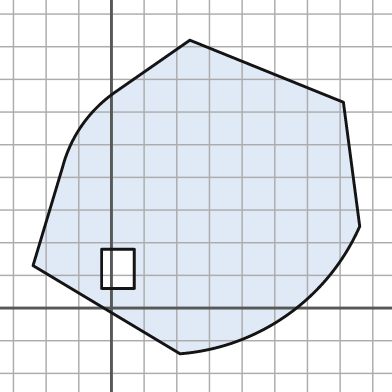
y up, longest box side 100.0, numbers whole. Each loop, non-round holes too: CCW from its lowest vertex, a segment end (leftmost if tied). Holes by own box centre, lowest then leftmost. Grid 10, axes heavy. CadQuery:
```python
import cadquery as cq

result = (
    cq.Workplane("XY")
    .moveTo(21.0, -14.0)
    .threePointArc((54.0, -2.0), (76.0, 25.0))
    .lineTo(71.0, 63.0)
    .lineTo(24.0, 82.0)
    .lineTo(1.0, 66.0)
    .threePointArc((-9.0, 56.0), (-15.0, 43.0))
    .lineTo(-24.0, 13.0)
    .close()
    .moveTo(-3.0, 6.0)
    .lineTo(7.0, 6.0)
    .lineTo(7.0, 18.0)
    .lineTo(-3.0, 18.0)
    .close()
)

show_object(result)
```